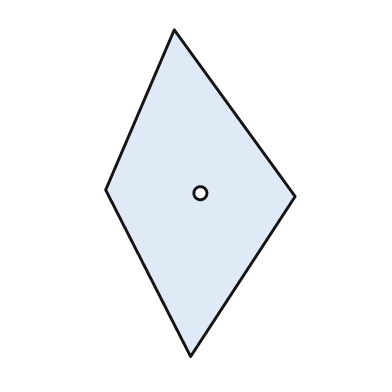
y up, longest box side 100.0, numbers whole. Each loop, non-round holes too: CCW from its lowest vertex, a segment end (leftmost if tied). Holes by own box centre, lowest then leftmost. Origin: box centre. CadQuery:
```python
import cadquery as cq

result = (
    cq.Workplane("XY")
    .moveTo(-3.0, -50.0)
    .lineTo(29.0, -1.0)
    .lineTo(-8.0, 50.0)
    .lineTo(-29.0, 1.0)
    .close()
    .moveTo(0.0, 0.0)
    .circle(2.0)
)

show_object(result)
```